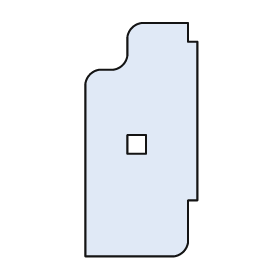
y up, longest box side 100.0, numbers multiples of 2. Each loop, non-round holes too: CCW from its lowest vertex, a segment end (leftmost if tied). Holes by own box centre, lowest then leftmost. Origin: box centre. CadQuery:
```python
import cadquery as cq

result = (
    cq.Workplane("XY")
    .moveTo(-24.0, -50.0)
    .lineTo(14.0, -50.0)
    .threePointArc((18.0, -48.0), (20.0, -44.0))
    .lineTo(20.0, -26.0)
    .lineTo(24.0, -26.0)
    .lineTo(24.0, 42.0)
    .lineTo(20.0, 42.0)
    .lineTo(20.0, 50.0)
    .lineTo(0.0, 50.0)
    .threePointArc((-4.0, 48.0), (-6.0, 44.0))
    .lineTo(-6.0, 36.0)
    .threePointArc((-8.0, 32.0), (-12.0, 30.0))
    .lineTo(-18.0, 30.0)
    .threePointArc((-22.0, 28.0), (-24.0, 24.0))
    .close()
    .moveTo(-6.0, -6.0)
    .lineTo(2.0, -6.0)
    .lineTo(2.0, 2.0)
    .lineTo(-6.0, 2.0)
    .close()
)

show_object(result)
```